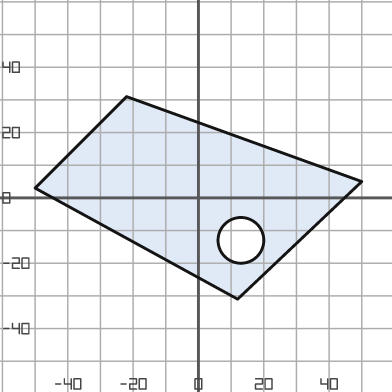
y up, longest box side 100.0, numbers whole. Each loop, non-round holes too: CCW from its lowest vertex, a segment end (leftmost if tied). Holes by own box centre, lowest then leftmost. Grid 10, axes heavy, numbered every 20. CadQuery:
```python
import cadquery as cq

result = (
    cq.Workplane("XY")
    .moveTo(12.0, -31.0)
    .lineTo(50.0, 5.0)
    .lineTo(-22.0, 31.0)
    .lineTo(-50.0, 3.0)
    .close()
    .moveTo(13.0, -13.0)
    .circle(7.0)
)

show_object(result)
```